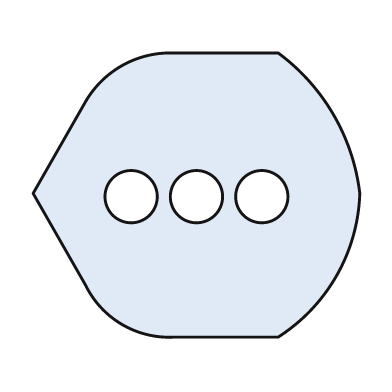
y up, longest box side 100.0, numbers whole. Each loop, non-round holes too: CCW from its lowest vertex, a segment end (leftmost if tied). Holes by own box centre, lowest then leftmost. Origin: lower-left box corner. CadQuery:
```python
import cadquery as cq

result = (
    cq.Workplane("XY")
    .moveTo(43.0, 0.0)
    .lineTo(75.0, 0.0)
    .threePointArc((93.0, 19.0), (100.0, 44.0))
    .threePointArc((92.0, 68.0), (75.0, 87.0))
    .lineTo(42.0, 87.0)
    .threePointArc((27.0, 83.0), (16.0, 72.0))
    .lineTo(0.0, 44.0)
    .lineTo(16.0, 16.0)
    .threePointArc((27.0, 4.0), (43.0, 0.0))
    .close()
    .moveTo(30.0, 43.0)
    .circle(8.0)
    .moveTo(50.0, 43.0)
    .circle(8.0)
    .moveTo(70.0, 43.0)
    .circle(8.0)
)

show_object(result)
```